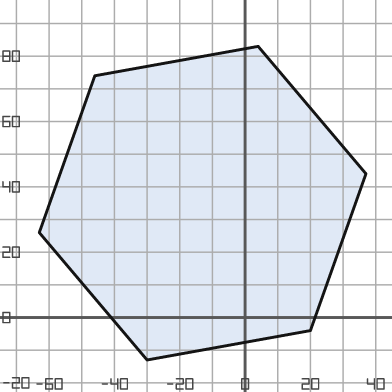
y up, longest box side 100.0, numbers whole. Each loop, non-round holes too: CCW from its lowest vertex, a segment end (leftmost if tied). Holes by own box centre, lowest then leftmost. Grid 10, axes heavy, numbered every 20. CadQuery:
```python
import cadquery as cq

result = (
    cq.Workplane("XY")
    .moveTo(-30.0, -13.0)
    .lineTo(20.0, -4.0)
    .lineTo(37.0, 44.0)
    .lineTo(4.0, 83.0)
    .lineTo(-46.0, 74.0)
    .lineTo(-63.0, 26.0)
    .close()
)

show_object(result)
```